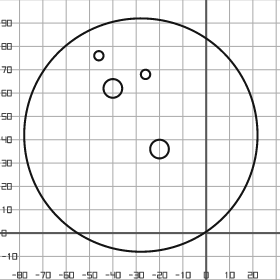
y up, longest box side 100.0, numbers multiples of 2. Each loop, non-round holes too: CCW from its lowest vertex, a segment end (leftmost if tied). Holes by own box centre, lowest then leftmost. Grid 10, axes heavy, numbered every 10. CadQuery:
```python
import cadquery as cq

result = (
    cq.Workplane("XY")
    .moveTo(-28.0, 42.0)
    .circle(50.0)
    .moveTo(-20.0, 36.0)
    .circle(4.0)
    .moveTo(-40.0, 62.0)
    .circle(4.0)
    .moveTo(-26.0, 68.0)
    .circle(2.0)
    .moveTo(-46.0, 76.0)
    .circle(2.0)
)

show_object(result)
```